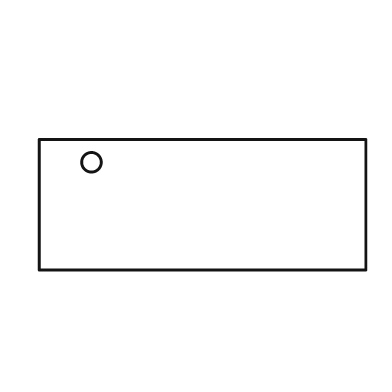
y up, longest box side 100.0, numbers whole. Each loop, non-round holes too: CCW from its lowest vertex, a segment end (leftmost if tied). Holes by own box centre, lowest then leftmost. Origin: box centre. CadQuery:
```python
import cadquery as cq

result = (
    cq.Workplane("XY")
    .moveTo(-50.0, -20.0)
    .lineTo(50.0, -20.0)
    .lineTo(50.0, 20.0)
    .lineTo(-50.0, 20.0)
    .close()
    .moveTo(-34.0, 13.0)
    .circle(3.0)
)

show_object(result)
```